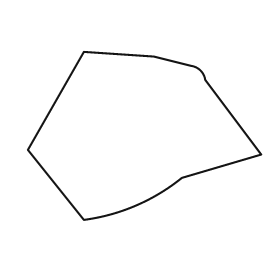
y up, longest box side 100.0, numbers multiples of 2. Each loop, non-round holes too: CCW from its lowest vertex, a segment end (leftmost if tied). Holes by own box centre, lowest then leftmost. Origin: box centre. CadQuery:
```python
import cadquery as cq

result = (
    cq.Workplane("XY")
    .moveTo(-26.0, -36.0)
    .threePointArc((-4.0, -30.0), (16.0, -18.0))
    .lineTo(50.0, -8.0)
    .lineTo(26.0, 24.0)
    .threePointArc((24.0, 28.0), (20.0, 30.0))
    .lineTo(4.0, 34.0)
    .lineTo(-26.0, 36.0)
    .lineTo(-50.0, -6.0)
    .close()
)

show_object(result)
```